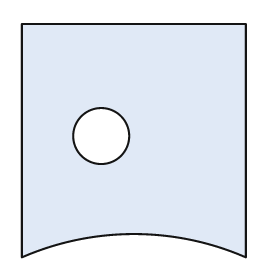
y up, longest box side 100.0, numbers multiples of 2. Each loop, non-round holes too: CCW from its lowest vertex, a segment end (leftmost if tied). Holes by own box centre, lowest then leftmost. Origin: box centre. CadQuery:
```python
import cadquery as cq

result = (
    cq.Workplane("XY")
    .moveTo(-48.0, -50.0)
    .threePointArc((0.0, -40.0), (48.0, -50.0))
    .lineTo(48.0, 50.0)
    .lineTo(-48.0, 50.0)
    .close()
    .moveTo(-14.0, 2.0)
    .circle(12.0)
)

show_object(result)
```